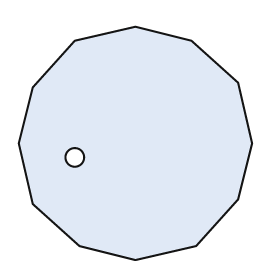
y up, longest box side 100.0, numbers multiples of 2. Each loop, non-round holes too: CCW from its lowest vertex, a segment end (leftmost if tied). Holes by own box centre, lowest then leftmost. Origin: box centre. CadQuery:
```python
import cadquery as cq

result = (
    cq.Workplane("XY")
    .moveTo(0.0, -50.0)
    .lineTo(26.0, -44.0)
    .lineTo(44.0, -24.0)
    .lineTo(50.0, 0.0)
    .lineTo(44.0, 26.0)
    .lineTo(24.0, 44.0)
    .lineTo(0.0, 50.0)
    .lineTo(-26.0, 44.0)
    .lineTo(-44.0, 24.0)
    .lineTo(-50.0, 0.0)
    .lineTo(-44.0, -26.0)
    .lineTo(-24.0, -44.0)
    .close()
    .moveTo(-26.0, -6.0)
    .circle(4.0)
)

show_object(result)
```